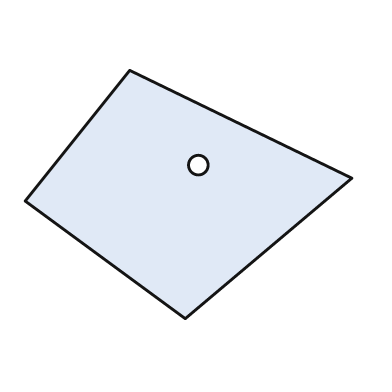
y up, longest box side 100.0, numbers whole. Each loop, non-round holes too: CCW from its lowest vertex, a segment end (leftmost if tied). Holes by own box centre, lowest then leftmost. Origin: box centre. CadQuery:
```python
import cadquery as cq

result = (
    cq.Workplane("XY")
    .moveTo(-1.0, -38.0)
    .lineTo(50.0, 5.0)
    .lineTo(-18.0, 38.0)
    .lineTo(-50.0, -2.0)
    .close()
    .moveTo(3.0, 9.0)
    .circle(3.0)
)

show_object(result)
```